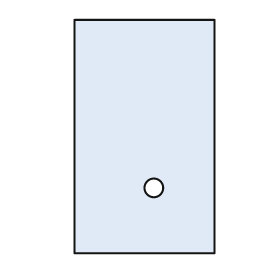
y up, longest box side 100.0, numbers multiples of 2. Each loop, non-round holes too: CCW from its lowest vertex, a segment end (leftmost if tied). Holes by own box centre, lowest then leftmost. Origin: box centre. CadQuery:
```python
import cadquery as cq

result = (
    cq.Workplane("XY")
    .moveTo(-30.0, -50.0)
    .lineTo(30.0, -50.0)
    .lineTo(30.0, 50.0)
    .lineTo(-30.0, 50.0)
    .close()
    .moveTo(4.0, -22.0)
    .circle(4.0)
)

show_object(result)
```